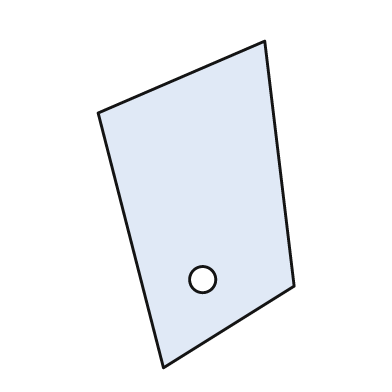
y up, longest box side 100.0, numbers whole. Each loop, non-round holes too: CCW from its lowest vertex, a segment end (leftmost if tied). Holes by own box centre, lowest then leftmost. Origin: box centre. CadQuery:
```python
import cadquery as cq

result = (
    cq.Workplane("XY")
    .moveTo(-10.0, -50.0)
    .lineTo(30.0, -25.0)
    .lineTo(21.0, 50.0)
    .lineTo(-30.0, 28.0)
    .close()
    .moveTo(2.0, -23.0)
    .circle(4.0)
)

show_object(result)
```